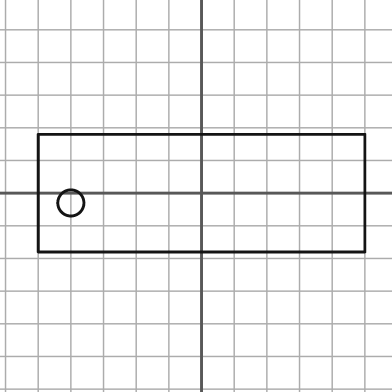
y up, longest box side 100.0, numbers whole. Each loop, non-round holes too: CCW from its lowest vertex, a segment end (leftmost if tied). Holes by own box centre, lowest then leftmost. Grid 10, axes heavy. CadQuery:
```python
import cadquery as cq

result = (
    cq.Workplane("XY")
    .moveTo(-50.0, -18.0)
    .lineTo(50.0, -18.0)
    .lineTo(50.0, 18.0)
    .lineTo(-50.0, 18.0)
    .close()
    .moveTo(-40.0, -3.0)
    .circle(4.0)
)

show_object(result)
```